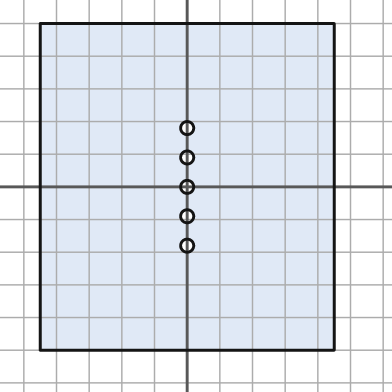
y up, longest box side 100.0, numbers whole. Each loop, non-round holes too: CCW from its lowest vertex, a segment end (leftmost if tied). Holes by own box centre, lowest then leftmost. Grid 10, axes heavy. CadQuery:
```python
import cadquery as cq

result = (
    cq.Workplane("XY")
    .moveTo(-45.0, -50.0)
    .lineTo(45.0, -50.0)
    .lineTo(45.0, 50.0)
    .lineTo(-45.0, 50.0)
    .close()
    .moveTo(0.0, -18.0)
    .circle(2.0)
    .moveTo(0.0, -9.0)
    .circle(2.0)
    .moveTo(0.0, 0.0)
    .circle(2.0)
    .moveTo(0.0, 9.0)
    .circle(2.0)
    .moveTo(0.0, 18.0)
    .circle(2.0)
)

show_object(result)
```